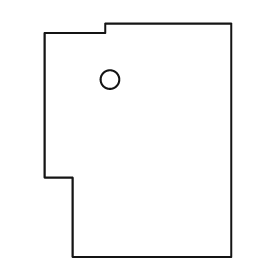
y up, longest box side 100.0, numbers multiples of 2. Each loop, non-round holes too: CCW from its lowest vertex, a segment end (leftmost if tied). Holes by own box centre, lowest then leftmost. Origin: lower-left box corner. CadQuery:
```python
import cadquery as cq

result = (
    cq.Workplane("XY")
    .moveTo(12.0, 0.0)
    .lineTo(80.0, 0.0)
    .lineTo(80.0, 100.0)
    .lineTo(26.0, 100.0)
    .lineTo(26.0, 96.0)
    .lineTo(0.0, 96.0)
    .lineTo(0.0, 34.0)
    .lineTo(12.0, 34.0)
    .close()
    .moveTo(28.0, 76.0)
    .circle(4.0)
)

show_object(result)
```